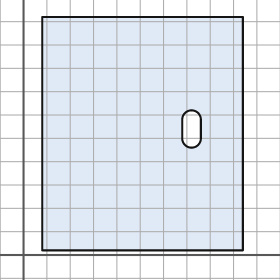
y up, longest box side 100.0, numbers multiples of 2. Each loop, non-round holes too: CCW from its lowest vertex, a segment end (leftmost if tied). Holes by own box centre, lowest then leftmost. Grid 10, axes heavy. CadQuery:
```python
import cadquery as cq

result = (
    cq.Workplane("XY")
    .moveTo(8.0, 2.0)
    .lineTo(94.0, 2.0)
    .lineTo(94.0, 102.0)
    .lineTo(8.0, 102.0)
    .close()
    .moveTo(68.0, 50.0)
    .threePointArc((72.0, 46.0), (76.0, 50.0))
    .lineTo(76.0, 58.0)
    .threePointArc((72.0, 62.0), (68.0, 58.0))
    .close()
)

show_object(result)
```